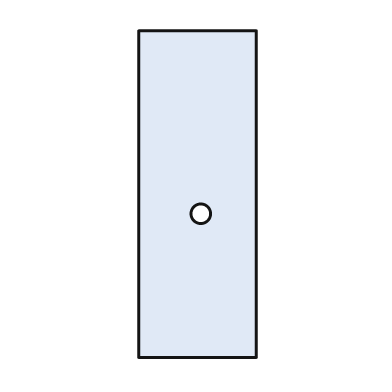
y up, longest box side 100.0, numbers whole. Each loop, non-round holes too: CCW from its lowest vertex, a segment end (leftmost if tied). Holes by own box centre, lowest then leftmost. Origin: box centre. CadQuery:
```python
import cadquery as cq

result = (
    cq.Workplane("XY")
    .moveTo(-18.0, -50.0)
    .lineTo(18.0, -50.0)
    .lineTo(18.0, 50.0)
    .lineTo(-18.0, 50.0)
    .close()
    .moveTo(1.0, -6.0)
    .circle(3.0)
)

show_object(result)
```